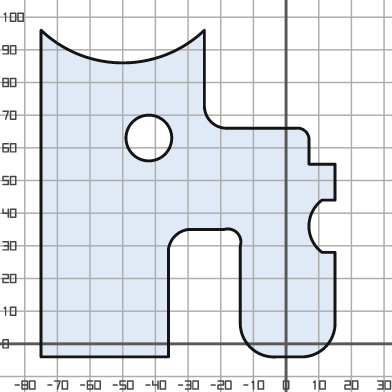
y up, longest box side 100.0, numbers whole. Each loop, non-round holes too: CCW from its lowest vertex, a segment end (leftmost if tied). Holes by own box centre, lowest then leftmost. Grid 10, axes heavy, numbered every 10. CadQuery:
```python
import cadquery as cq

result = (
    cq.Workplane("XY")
    .moveTo(-75.0, -4.0)
    .lineTo(-36.0, -4.0)
    .lineTo(-36.0, 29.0)
    .threePointArc((-34.0, 33.0), (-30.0, 35.0))
    .lineTo(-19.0, 35.0)
    .threePointArc((-15.0, 34.0), (-14.0, 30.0))
    .lineTo(-14.0, 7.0)
    .threePointArc((-11.0, -1.0), (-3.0, -4.0))
    .lineTo(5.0, -4.0)
    .threePointArc((12.0, -1.0), (15.0, 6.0))
    .lineTo(15.0, 28.0)
    .lineTo(11.0, 28.0)
    .threePointArc((7.0, 36.0), (11.0, 44.0))
    .lineTo(15.0, 44.0)
    .lineTo(15.0, 55.0)
    .lineTo(7.0, 55.0)
    .lineTo(7.0, 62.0)
    .threePointArc((6.0, 65.0), (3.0, 66.0))
    .lineTo(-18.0, 66.0)
    .threePointArc((-23.0, 68.0), (-25.0, 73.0))
    .lineTo(-25.0, 96.0)
    .threePointArc((-50.0, 86.0), (-75.0, 96.0))
    .close()
    .moveTo(-42.0, 63.0)
    .circle(7.0)
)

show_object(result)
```